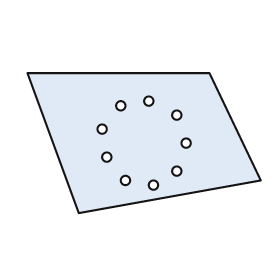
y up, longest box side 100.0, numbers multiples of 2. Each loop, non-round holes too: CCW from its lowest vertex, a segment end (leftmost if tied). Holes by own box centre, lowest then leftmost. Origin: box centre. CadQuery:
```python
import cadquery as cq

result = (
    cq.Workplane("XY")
    .moveTo(-28.0, -30.0)
    .lineTo(50.0, -16.0)
    .lineTo(28.0, 30.0)
    .lineTo(-50.0, 30.0)
    .close()
    .moveTo(4.0, -18.0)
    .circle(2.0)
    .moveTo(-8.0, -16.0)
    .circle(2.0)
    .moveTo(14.0, -12.0)
    .circle(2.0)
    .moveTo(-16.0, -6.0)
    .circle(2.0)
    .moveTo(18.0, 0.0)
    .circle(2.0)
    .moveTo(-18.0, 6.0)
    .circle(2.0)
    .moveTo(14.0, 12.0)
    .circle(2.0)
    .moveTo(-10.0, 16.0)
    .circle(2.0)
    .moveTo(2.0, 18.0)
    .circle(2.0)
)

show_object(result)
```